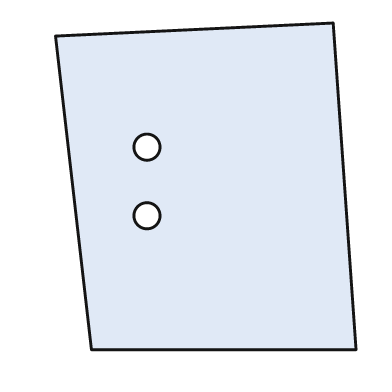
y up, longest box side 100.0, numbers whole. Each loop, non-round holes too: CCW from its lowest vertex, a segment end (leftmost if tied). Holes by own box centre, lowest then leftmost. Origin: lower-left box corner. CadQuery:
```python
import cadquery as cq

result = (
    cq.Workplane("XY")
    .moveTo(11.0, 0.0)
    .lineTo(92.0, 0.0)
    .lineTo(85.0, 100.0)
    .lineTo(0.0, 96.0)
    .close()
    .moveTo(28.0, 41.0)
    .circle(4.0)
    .moveTo(28.0, 62.0)
    .circle(4.0)
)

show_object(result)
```